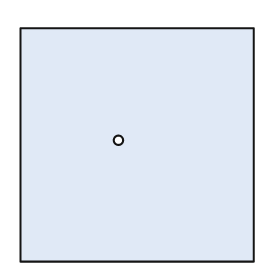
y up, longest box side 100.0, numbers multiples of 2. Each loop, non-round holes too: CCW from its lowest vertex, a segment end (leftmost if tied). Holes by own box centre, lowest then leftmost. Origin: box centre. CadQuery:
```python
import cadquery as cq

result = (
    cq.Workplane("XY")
    .moveTo(-50.0, -50.0)
    .lineTo(50.0, -50.0)
    .lineTo(50.0, 50.0)
    .lineTo(-50.0, 50.0)
    .close()
    .moveTo(-8.0, 2.0)
    .circle(2.0)
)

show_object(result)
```